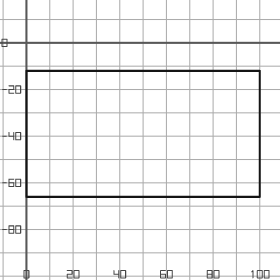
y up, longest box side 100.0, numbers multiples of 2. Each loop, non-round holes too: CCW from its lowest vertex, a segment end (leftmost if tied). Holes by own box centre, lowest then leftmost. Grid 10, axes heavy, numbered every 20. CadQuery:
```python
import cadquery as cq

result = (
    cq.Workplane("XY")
    .moveTo(0.0, -66.0)
    .lineTo(100.0, -66.0)
    .lineTo(100.0, -12.0)
    .lineTo(0.0, -12.0)
    .close()
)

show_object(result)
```